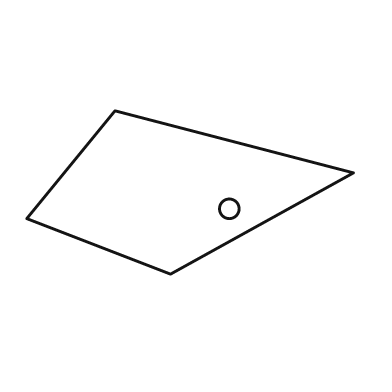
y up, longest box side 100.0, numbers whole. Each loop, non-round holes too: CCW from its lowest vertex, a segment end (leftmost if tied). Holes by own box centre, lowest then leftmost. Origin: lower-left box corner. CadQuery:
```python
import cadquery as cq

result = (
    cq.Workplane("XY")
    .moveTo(44.0, 0.0)
    .lineTo(100.0, 31.0)
    .lineTo(27.0, 50.0)
    .lineTo(0.0, 17.0)
    .close()
    .moveTo(62.0, 20.0)
    .circle(3.0)
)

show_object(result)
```